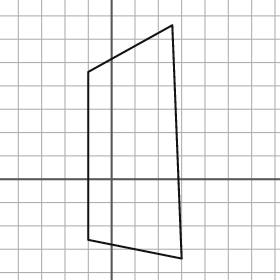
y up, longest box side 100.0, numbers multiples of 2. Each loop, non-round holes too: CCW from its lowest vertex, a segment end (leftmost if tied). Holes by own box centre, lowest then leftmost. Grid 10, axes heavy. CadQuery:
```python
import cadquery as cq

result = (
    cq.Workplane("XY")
    .moveTo(30.0, -34.0)
    .lineTo(26.0, 66.0)
    .lineTo(-10.0, 46.0)
    .lineTo(-10.0, -26.0)
    .close()
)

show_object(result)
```